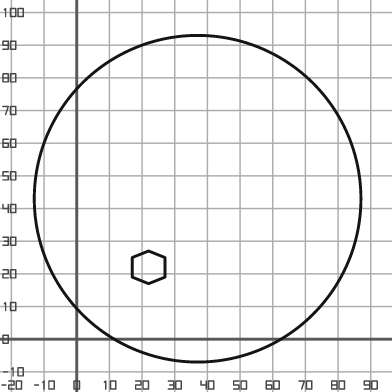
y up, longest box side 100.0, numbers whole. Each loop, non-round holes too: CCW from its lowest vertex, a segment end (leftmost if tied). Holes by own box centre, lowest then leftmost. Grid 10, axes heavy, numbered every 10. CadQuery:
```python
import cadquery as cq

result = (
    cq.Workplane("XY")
    .moveTo(37.0, 43.0)
    .circle(50.0)
    .moveTo(22.0, 17.0)
    .lineTo(27.0, 19.0)
    .lineTo(27.0, 25.0)
    .lineTo(22.0, 27.0)
    .lineTo(17.0, 25.0)
    .lineTo(17.0, 19.0)
    .close()
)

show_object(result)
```